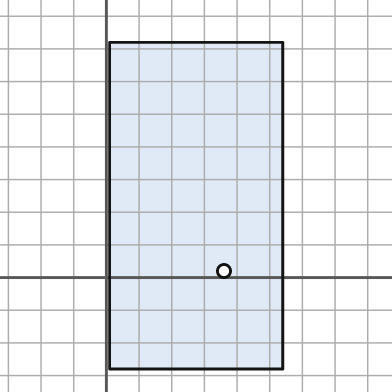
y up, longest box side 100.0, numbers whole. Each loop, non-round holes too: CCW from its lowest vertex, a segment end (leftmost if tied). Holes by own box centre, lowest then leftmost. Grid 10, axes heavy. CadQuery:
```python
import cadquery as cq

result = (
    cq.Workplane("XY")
    .moveTo(1.0, -28.0)
    .lineTo(54.0, -28.0)
    .lineTo(54.0, 72.0)
    .lineTo(1.0, 72.0)
    .close()
    .moveTo(36.0, 2.0)
    .circle(2.0)
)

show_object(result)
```